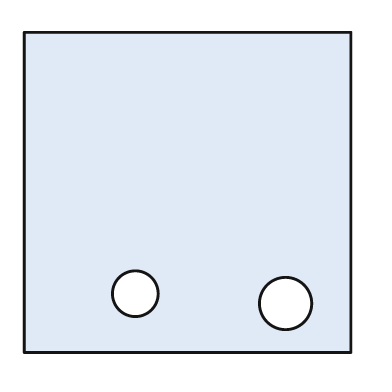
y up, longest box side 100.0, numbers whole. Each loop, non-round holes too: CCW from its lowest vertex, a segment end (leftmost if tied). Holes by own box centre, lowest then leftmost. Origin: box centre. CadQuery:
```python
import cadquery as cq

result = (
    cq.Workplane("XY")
    .moveTo(-50.0, -49.0)
    .lineTo(50.0, -49.0)
    .lineTo(50.0, 49.0)
    .lineTo(-50.0, 49.0)
    .close()
    .moveTo(30.0, -34.0)
    .circle(8.0)
    .moveTo(-16.0, -31.0)
    .circle(7.0)
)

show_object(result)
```